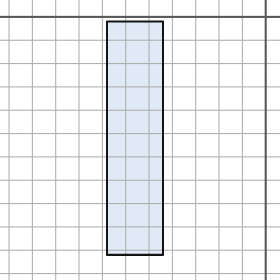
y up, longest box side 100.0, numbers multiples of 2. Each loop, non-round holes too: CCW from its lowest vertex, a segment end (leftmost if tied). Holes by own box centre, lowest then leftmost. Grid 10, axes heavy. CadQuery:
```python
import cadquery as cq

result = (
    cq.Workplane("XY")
    .moveTo(-68.0, -102.0)
    .lineTo(-44.0, -102.0)
    .lineTo(-44.0, -2.0)
    .lineTo(-68.0, -2.0)
    .close()
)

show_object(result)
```